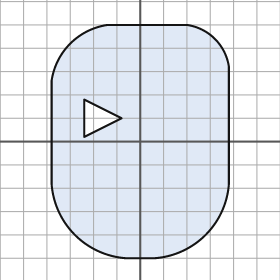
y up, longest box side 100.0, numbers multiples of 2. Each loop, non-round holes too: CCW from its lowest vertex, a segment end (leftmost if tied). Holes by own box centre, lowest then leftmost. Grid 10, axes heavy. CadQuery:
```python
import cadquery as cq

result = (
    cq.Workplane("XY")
    .moveTo(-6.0, -50.0)
    .lineTo(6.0, -50.0)
    .threePointArc((28.0, -40.0), (38.0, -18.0))
    .lineTo(38.0, 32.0)
    .threePointArc((32.0, 44.0), (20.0, 50.0))
    .lineTo(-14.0, 50.0)
    .threePointArc((-30.0, 42.0), (-38.0, 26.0))
    .lineTo(-38.0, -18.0)
    .threePointArc((-28.0, -40.0), (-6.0, -50.0))
    .close()
    .moveTo(-24.0, 2.0)
    .lineTo(-8.0, 10.0)
    .lineTo(-24.0, 18.0)
    .close()
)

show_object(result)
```